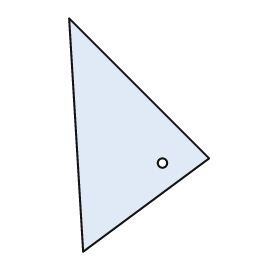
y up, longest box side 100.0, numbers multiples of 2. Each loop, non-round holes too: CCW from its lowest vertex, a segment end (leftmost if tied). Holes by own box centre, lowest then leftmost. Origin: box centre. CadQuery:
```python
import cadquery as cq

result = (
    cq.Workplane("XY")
    .moveTo(-24.0, -50.0)
    .lineTo(30.0, -10.0)
    .lineTo(-30.0, 50.0)
    .close()
    .moveTo(10.0, -12.0)
    .circle(2.0)
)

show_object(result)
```